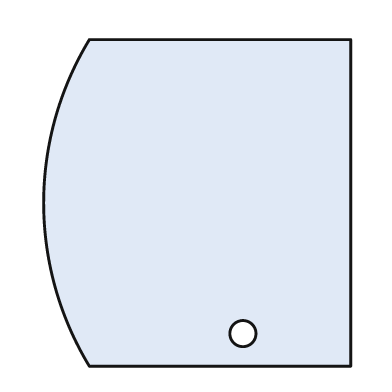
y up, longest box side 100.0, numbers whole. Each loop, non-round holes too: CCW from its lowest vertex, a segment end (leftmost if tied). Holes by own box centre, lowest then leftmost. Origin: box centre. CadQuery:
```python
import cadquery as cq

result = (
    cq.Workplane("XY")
    .moveTo(-33.0, -50.0)
    .lineTo(47.0, -50.0)
    .lineTo(47.0, 50.0)
    .lineTo(-33.0, 50.0)
    .threePointArc((-47.0, 0.0), (-33.0, -50.0))
    .close()
    .moveTo(14.0, -40.0)
    .circle(4.0)
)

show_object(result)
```